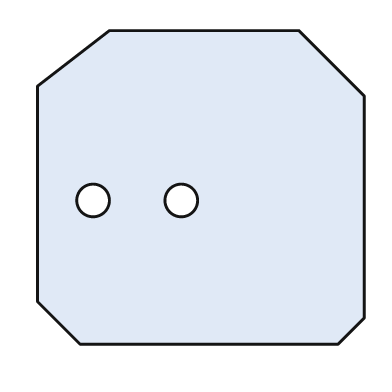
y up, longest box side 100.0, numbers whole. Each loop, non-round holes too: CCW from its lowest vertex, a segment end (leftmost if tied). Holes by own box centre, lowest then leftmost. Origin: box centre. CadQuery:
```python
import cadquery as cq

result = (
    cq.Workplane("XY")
    .moveTo(-37.0, -48.0)
    .lineTo(42.0, -48.0)
    .lineTo(50.0, -40.0)
    .lineTo(50.0, 28.0)
    .lineTo(30.0, 48.0)
    .lineTo(-28.0, 48.0)
    .lineTo(-50.0, 31.0)
    .lineTo(-50.0, -35.0)
    .close()
    .moveTo(-33.0, -4.0)
    .circle(5.0)
    .moveTo(-6.0, -4.0)
    .circle(5.0)
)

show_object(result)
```